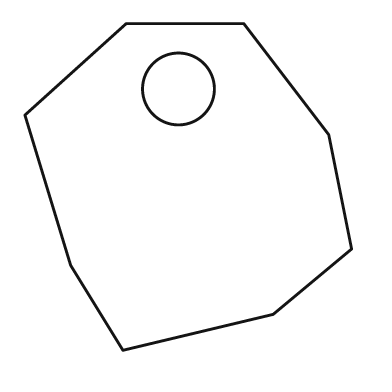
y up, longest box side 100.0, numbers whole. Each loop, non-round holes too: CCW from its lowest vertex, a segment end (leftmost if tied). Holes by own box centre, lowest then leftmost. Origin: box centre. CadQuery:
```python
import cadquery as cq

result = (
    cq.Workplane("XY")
    .moveTo(-20.0, -50.0)
    .lineTo(26.0, -39.0)
    .lineTo(50.0, -19.0)
    .lineTo(43.0, 16.0)
    .lineTo(17.0, 50.0)
    .lineTo(-19.0, 50.0)
    .lineTo(-50.0, 22.0)
    .lineTo(-36.0, -24.0)
    .close()
    .moveTo(-3.0, 30.0)
    .circle(11.0)
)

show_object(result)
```